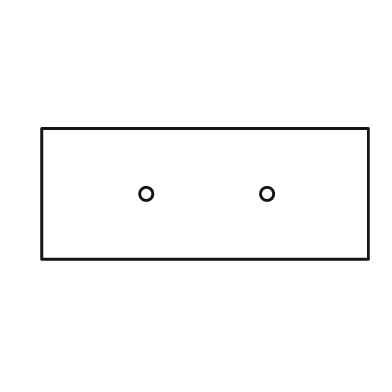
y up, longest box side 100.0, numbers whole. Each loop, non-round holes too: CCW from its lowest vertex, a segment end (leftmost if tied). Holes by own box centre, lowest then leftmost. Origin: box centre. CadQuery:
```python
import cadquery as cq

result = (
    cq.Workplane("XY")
    .moveTo(-50.0, -20.0)
    .lineTo(50.0, -20.0)
    .lineTo(50.0, 20.0)
    .lineTo(-50.0, 20.0)
    .close()
    .moveTo(-18.0, 0.0)
    .circle(2.0)
    .moveTo(19.0, 0.0)
    .circle(2.0)
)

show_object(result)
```